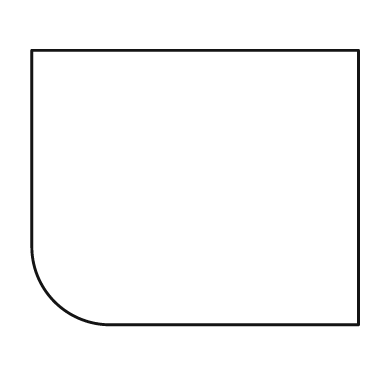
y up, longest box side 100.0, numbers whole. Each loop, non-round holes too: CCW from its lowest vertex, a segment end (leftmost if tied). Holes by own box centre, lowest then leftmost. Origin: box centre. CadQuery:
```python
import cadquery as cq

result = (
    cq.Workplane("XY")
    .moveTo(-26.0, -42.0)
    .lineTo(50.0, -42.0)
    .lineTo(50.0, 42.0)
    .lineTo(-50.0, 42.0)
    .lineTo(-50.0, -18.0)
    .threePointArc((-43.0, -35.0), (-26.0, -42.0))
    .close()
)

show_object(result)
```